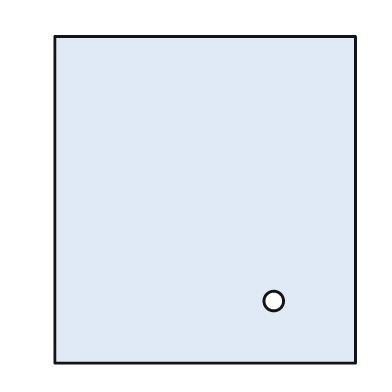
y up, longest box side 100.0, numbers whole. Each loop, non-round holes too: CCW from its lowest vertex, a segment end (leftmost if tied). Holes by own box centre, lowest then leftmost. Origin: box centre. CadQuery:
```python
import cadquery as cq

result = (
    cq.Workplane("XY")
    .moveTo(-46.0, -50.0)
    .lineTo(46.0, -50.0)
    .lineTo(46.0, 50.0)
    .lineTo(-46.0, 50.0)
    .close()
    .moveTo(21.0, -31.0)
    .circle(3.0)
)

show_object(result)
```